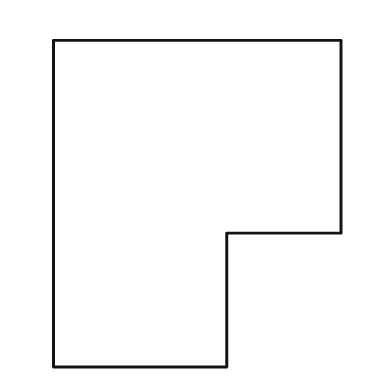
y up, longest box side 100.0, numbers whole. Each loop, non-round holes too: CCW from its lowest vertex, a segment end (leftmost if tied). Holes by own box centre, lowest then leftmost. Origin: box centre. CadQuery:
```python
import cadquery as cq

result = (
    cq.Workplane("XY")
    .moveTo(-44.0, -50.0)
    .lineTo(9.0, -50.0)
    .lineTo(9.0, -9.0)
    .lineTo(44.0, -9.0)
    .lineTo(44.0, 50.0)
    .lineTo(-44.0, 50.0)
    .close()
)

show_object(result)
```